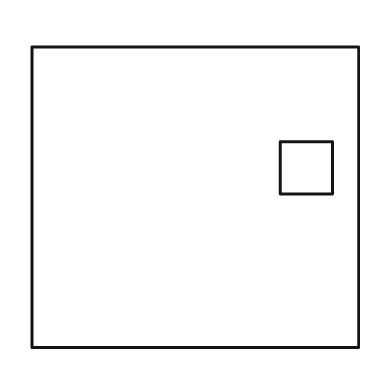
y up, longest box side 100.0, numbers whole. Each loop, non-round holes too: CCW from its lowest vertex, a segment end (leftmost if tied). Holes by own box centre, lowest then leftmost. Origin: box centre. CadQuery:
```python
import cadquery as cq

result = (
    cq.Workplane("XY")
    .moveTo(-50.0, -46.0)
    .lineTo(50.0, -46.0)
    .lineTo(50.0, 46.0)
    .lineTo(-50.0, 46.0)
    .close()
    .moveTo(26.0, 1.0)
    .lineTo(42.0, 1.0)
    .lineTo(42.0, 17.0)
    .lineTo(26.0, 17.0)
    .close()
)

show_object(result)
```